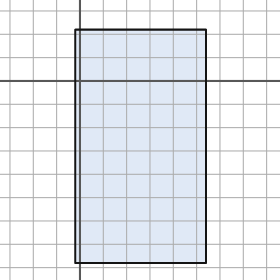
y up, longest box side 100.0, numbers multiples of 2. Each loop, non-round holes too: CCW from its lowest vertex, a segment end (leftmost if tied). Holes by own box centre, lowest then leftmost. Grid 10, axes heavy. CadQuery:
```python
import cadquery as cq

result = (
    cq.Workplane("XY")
    .moveTo(-2.0, -78.0)
    .lineTo(54.0, -78.0)
    .lineTo(54.0, 22.0)
    .lineTo(-2.0, 22.0)
    .close()
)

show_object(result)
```